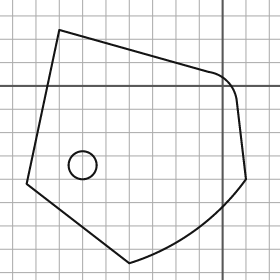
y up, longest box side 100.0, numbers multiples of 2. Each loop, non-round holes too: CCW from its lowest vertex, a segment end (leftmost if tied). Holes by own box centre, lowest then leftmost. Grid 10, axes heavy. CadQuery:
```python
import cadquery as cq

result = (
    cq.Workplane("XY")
    .moveTo(-40.0, -76.0)
    .threePointArc((-12.0, -62.0), (10.0, -40.0))
    .lineTo(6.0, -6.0)
    .threePointArc((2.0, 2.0), (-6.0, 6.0))
    .lineTo(-70.0, 24.0)
    .lineTo(-84.0, -42.0)
    .close()
    .moveTo(-60.0, -34.0)
    .circle(6.0)
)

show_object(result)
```